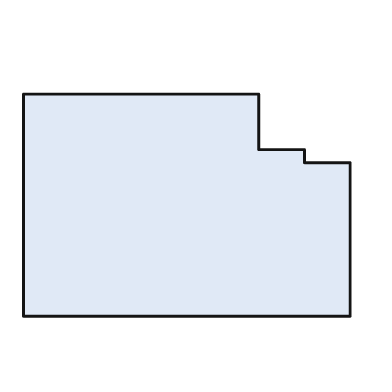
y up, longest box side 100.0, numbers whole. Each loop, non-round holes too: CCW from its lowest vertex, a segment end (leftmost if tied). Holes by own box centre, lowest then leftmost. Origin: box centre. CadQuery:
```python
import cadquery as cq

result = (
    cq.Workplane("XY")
    .moveTo(-50.0, -34.0)
    .lineTo(50.0, -34.0)
    .lineTo(50.0, 13.0)
    .lineTo(36.0, 13.0)
    .lineTo(36.0, 17.0)
    .lineTo(22.0, 17.0)
    .lineTo(22.0, 34.0)
    .lineTo(-50.0, 34.0)
    .close()
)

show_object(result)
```